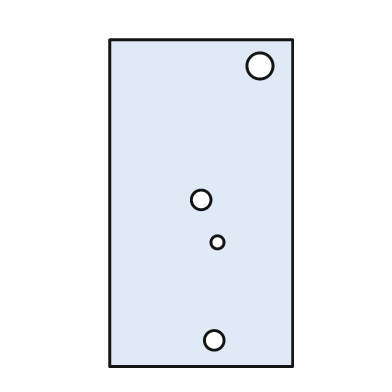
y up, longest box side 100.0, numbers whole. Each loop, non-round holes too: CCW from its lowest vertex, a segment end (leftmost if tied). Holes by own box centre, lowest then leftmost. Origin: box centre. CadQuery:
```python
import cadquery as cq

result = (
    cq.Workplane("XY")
    .moveTo(-28.0, -50.0)
    .lineTo(28.0, -50.0)
    .lineTo(28.0, 50.0)
    .lineTo(-28.0, 50.0)
    .close()
    .moveTo(4.0, -42.0)
    .circle(3.0)
    .moveTo(5.0, -12.0)
    .circle(2.0)
    .moveTo(0.0, 1.0)
    .circle(3.0)
    .moveTo(18.0, 42.0)
    .circle(4.0)
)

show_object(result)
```